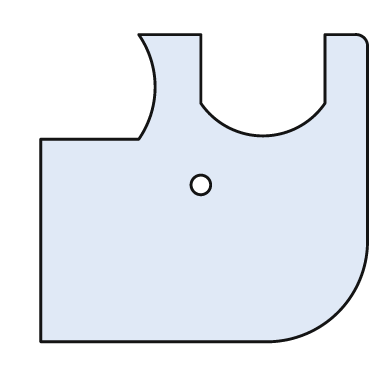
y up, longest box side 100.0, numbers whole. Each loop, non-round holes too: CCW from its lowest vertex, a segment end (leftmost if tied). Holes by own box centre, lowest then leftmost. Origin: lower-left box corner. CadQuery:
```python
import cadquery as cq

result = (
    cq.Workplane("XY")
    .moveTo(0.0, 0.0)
    .lineTo(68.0, 0.0)
    .threePointArc((91.0, 9.0), (100.0, 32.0))
    .lineTo(100.0, 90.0)
    .threePointArc((99.0, 93.0), (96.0, 94.0))
    .lineTo(87.0, 94.0)
    .lineTo(87.0, 73.0)
    .threePointArc((68.0, 63.0), (49.0, 73.0))
    .lineTo(49.0, 94.0)
    .lineTo(30.0, 94.0)
    .threePointArc((35.0, 78.0), (30.0, 62.0))
    .lineTo(0.0, 62.0)
    .close()
    .moveTo(49.0, 48.0)
    .circle(3.0)
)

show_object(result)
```